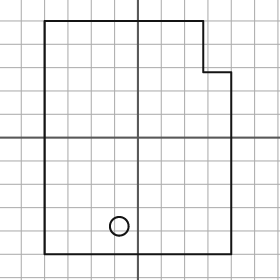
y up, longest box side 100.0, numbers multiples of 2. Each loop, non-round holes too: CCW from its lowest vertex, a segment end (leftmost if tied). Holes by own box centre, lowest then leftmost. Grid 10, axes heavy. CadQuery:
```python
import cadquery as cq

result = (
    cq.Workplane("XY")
    .moveTo(-40.0, -50.0)
    .lineTo(40.0, -50.0)
    .lineTo(40.0, 28.0)
    .lineTo(28.0, 28.0)
    .lineTo(28.0, 50.0)
    .lineTo(-40.0, 50.0)
    .close()
    .moveTo(-8.0, -38.0)
    .circle(4.0)
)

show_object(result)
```